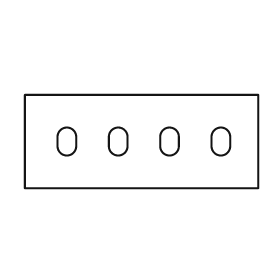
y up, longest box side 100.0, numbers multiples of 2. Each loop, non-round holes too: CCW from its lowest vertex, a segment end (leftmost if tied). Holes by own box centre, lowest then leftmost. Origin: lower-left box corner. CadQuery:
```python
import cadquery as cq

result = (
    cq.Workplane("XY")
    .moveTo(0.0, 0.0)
    .lineTo(100.0, 0.0)
    .lineTo(100.0, 40.0)
    .lineTo(0.0, 40.0)
    .close()
    .moveTo(14.0, 18.0)
    .threePointArc((18.0, 14.0), (22.0, 18.0))
    .lineTo(22.0, 22.0)
    .threePointArc((18.0, 26.0), (14.0, 22.0))
    .close()
    .moveTo(36.0, 18.0)
    .threePointArc((40.0, 14.0), (44.0, 18.0))
    .lineTo(44.0, 22.0)
    .threePointArc((40.0, 26.0), (36.0, 22.0))
    .close()
    .moveTo(58.0, 18.0)
    .threePointArc((62.0, 14.0), (66.0, 18.0))
    .lineTo(66.0, 22.0)
    .threePointArc((62.0, 26.0), (58.0, 22.0))
    .close()
    .moveTo(80.0, 18.0)
    .threePointArc((84.0, 14.0), (88.0, 18.0))
    .lineTo(88.0, 22.0)
    .threePointArc((84.0, 26.0), (80.0, 22.0))
    .close()
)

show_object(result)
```